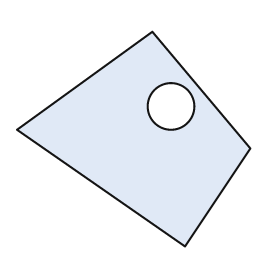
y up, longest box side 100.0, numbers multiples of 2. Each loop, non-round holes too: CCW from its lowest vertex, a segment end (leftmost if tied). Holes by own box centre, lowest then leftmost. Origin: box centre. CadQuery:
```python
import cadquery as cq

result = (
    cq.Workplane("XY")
    .moveTo(22.0, -46.0)
    .lineTo(50.0, -4.0)
    .lineTo(8.0, 46.0)
    .lineTo(-50.0, 4.0)
    .close()
    .moveTo(16.0, 14.0)
    .circle(10.0)
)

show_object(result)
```